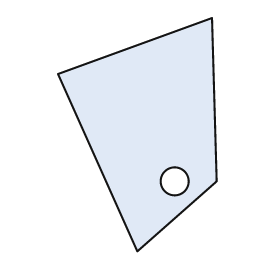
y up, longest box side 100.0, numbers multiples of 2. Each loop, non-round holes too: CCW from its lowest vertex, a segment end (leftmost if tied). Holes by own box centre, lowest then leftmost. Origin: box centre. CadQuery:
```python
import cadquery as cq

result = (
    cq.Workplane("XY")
    .moveTo(0.0, -50.0)
    .lineTo(34.0, -20.0)
    .lineTo(32.0, 50.0)
    .lineTo(-34.0, 26.0)
    .close()
    .moveTo(16.0, -20.0)
    .circle(6.0)
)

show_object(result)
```